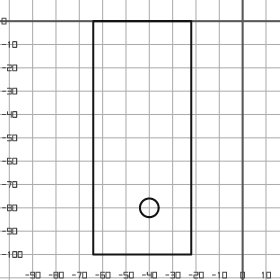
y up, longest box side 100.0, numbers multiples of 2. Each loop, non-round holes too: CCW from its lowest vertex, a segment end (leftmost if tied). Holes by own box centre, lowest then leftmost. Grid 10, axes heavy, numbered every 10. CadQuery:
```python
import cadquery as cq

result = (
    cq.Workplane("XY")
    .moveTo(-64.0, -100.0)
    .lineTo(-22.0, -100.0)
    .lineTo(-22.0, 0.0)
    .lineTo(-64.0, 0.0)
    .close()
    .moveTo(-40.0, -80.0)
    .circle(4.0)
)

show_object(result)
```